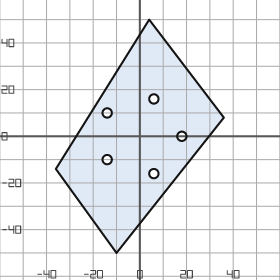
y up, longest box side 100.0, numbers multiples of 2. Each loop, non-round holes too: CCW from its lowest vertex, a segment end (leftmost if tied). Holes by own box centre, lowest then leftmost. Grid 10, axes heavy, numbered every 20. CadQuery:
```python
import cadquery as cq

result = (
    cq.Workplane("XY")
    .moveTo(-10.0, -50.0)
    .lineTo(36.0, 8.0)
    .lineTo(4.0, 50.0)
    .lineTo(-36.0, -14.0)
    .close()
    .moveTo(6.0, -16.0)
    .circle(2.0)
    .moveTo(-14.0, -10.0)
    .circle(2.0)
    .moveTo(18.0, 0.0)
    .circle(2.0)
    .moveTo(-14.0, 10.0)
    .circle(2.0)
    .moveTo(6.0, 16.0)
    .circle(2.0)
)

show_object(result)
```